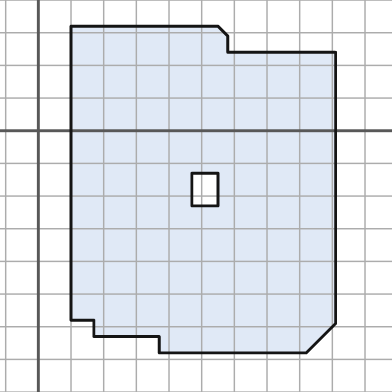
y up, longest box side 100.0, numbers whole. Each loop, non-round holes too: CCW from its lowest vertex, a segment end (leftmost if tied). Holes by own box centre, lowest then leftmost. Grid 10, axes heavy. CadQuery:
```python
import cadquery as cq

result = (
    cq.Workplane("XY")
    .moveTo(37.0, -68.0)
    .lineTo(82.0, -68.0)
    .lineTo(91.0, -59.0)
    .lineTo(91.0, 24.0)
    .lineTo(58.0, 24.0)
    .lineTo(58.0, 29.0)
    .lineTo(55.0, 32.0)
    .lineTo(10.0, 32.0)
    .lineTo(10.0, -58.0)
    .lineTo(17.0, -58.0)
    .lineTo(17.0, -63.0)
    .lineTo(37.0, -63.0)
    .close()
    .moveTo(47.0, -23.0)
    .lineTo(55.0, -23.0)
    .lineTo(55.0, -13.0)
    .lineTo(47.0, -13.0)
    .close()
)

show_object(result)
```